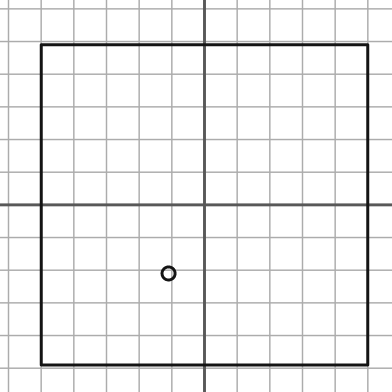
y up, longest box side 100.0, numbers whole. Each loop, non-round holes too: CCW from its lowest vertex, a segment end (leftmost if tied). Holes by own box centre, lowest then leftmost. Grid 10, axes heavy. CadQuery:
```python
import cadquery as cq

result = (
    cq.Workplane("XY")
    .moveTo(-50.0, -49.0)
    .lineTo(50.0, -49.0)
    .lineTo(50.0, 49.0)
    .lineTo(-50.0, 49.0)
    .close()
    .moveTo(-11.0, -21.0)
    .circle(2.0)
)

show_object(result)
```